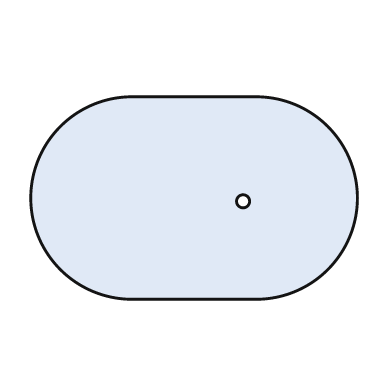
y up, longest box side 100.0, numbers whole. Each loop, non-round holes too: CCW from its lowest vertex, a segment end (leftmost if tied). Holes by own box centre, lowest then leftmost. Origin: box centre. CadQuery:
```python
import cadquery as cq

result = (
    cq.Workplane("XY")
    .moveTo(-19.0, -31.0)
    .lineTo(19.0, -31.0)
    .threePointArc((50.0, 0.0), (19.0, 31.0))
    .lineTo(-19.0, 31.0)
    .threePointArc((-50.0, 0.0), (-19.0, -31.0))
    .close()
    .moveTo(15.0, -1.0)
    .circle(2.0)
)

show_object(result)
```